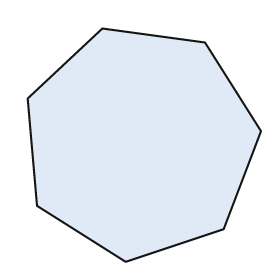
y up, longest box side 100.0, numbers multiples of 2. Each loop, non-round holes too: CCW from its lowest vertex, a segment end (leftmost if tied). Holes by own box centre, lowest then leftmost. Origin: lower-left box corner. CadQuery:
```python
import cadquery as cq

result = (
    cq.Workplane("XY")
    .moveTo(42.0, 0.0)
    .lineTo(84.0, 14.0)
    .lineTo(100.0, 56.0)
    .lineTo(76.0, 94.0)
    .lineTo(32.0, 100.0)
    .lineTo(0.0, 70.0)
    .lineTo(4.0, 24.0)
    .close()
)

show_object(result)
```